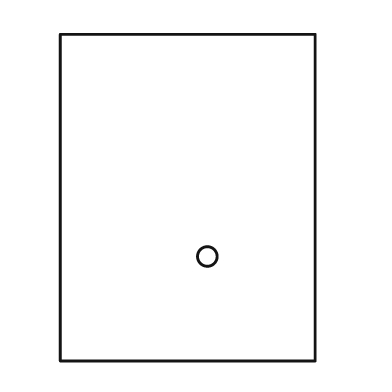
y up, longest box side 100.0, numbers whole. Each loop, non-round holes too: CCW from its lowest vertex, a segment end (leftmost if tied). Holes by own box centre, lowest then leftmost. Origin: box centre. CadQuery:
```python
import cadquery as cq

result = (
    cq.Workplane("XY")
    .moveTo(-39.0, -50.0)
    .lineTo(39.0, -50.0)
    .lineTo(39.0, 50.0)
    .lineTo(-39.0, 50.0)
    .close()
    .moveTo(6.0, -18.0)
    .circle(3.0)
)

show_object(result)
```